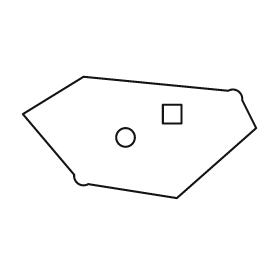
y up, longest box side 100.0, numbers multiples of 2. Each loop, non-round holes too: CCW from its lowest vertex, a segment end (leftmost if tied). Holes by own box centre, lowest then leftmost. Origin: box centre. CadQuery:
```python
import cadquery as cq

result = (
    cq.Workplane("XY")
    .moveTo(16.0, -26.0)
    .lineTo(50.0, 4.0)
    .lineTo(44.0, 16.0)
    .threePointArc((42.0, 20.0), (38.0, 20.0))
    .lineTo(-24.0, 26.0)
    .lineTo(-50.0, 10.0)
    .lineTo(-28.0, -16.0)
    .threePointArc((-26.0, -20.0), (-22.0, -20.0))
    .close()
    .moveTo(-6.0, 0.0)
    .circle(4.0)
    .moveTo(10.0, 6.0)
    .lineTo(18.0, 6.0)
    .lineTo(18.0, 14.0)
    .lineTo(10.0, 14.0)
    .close()
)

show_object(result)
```